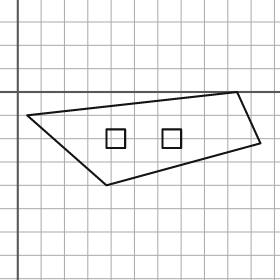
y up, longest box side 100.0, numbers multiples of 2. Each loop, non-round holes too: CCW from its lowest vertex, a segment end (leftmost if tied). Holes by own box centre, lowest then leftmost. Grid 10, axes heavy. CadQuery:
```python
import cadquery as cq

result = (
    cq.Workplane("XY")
    .moveTo(38.0, -40.0)
    .lineTo(104.0, -22.0)
    .lineTo(94.0, 0.0)
    .lineTo(4.0, -10.0)
    .close()
    .moveTo(38.0, -24.0)
    .lineTo(46.0, -24.0)
    .lineTo(46.0, -16.0)
    .lineTo(38.0, -16.0)
    .close()
    .moveTo(62.0, -24.0)
    .lineTo(70.0, -24.0)
    .lineTo(70.0, -16.0)
    .lineTo(62.0, -16.0)
    .close()
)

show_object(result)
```